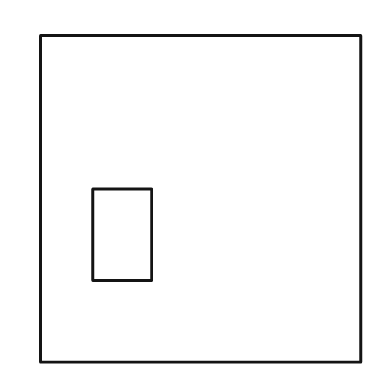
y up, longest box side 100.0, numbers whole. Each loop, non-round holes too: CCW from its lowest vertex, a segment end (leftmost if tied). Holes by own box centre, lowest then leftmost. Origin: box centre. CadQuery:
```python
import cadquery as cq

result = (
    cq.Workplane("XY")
    .moveTo(-49.0, -50.0)
    .lineTo(49.0, -50.0)
    .lineTo(49.0, 50.0)
    .lineTo(-49.0, 50.0)
    .close()
    .moveTo(-33.0, -25.0)
    .lineTo(-15.0, -25.0)
    .lineTo(-15.0, 3.0)
    .lineTo(-33.0, 3.0)
    .close()
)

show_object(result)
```